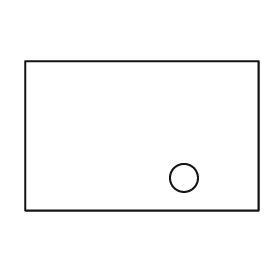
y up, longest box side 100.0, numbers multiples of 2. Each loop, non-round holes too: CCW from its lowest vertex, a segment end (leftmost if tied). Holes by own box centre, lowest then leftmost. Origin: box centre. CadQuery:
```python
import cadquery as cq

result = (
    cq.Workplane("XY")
    .moveTo(-50.0, -32.0)
    .lineTo(50.0, -32.0)
    .lineTo(50.0, 32.0)
    .lineTo(-50.0, 32.0)
    .close()
    .moveTo(18.0, -18.0)
    .circle(6.0)
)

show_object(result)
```